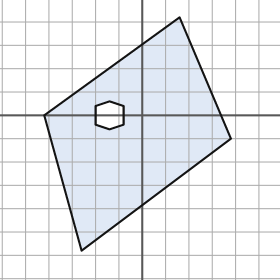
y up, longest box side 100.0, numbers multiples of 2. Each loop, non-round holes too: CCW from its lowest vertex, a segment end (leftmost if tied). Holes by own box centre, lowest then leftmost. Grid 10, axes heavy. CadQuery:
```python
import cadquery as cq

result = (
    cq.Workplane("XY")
    .moveTo(-26.0, -58.0)
    .lineTo(38.0, -10.0)
    .lineTo(16.0, 42.0)
    .lineTo(-42.0, 0.0)
    .close()
    .moveTo(-14.0, -6.0)
    .lineTo(-8.0, -4.0)
    .lineTo(-8.0, 4.0)
    .lineTo(-14.0, 6.0)
    .lineTo(-20.0, 4.0)
    .lineTo(-20.0, -4.0)
    .close()
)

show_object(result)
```